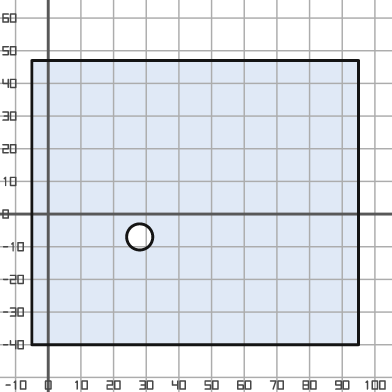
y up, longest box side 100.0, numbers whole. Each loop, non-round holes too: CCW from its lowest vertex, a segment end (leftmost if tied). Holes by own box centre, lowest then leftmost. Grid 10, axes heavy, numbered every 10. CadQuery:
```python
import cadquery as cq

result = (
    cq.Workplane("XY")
    .moveTo(-5.0, -40.0)
    .lineTo(95.0, -40.0)
    .lineTo(95.0, 47.0)
    .lineTo(-5.0, 47.0)
    .close()
    .moveTo(28.0, -7.0)
    .circle(4.0)
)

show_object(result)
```